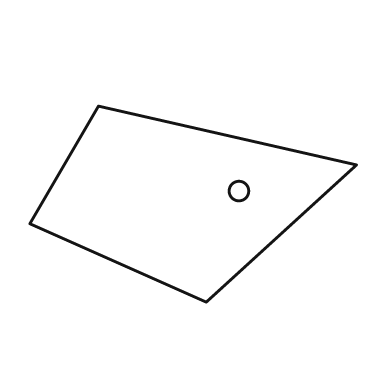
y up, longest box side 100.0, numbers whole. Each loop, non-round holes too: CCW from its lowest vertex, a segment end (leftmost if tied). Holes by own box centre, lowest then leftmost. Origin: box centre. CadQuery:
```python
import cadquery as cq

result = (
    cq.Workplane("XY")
    .moveTo(4.0, -30.0)
    .lineTo(50.0, 12.0)
    .lineTo(-29.0, 30.0)
    .lineTo(-50.0, -6.0)
    .close()
    .moveTo(14.0, 4.0)
    .circle(3.0)
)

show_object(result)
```